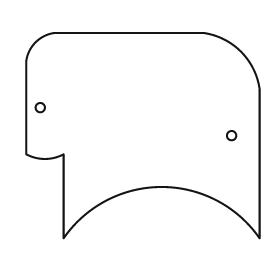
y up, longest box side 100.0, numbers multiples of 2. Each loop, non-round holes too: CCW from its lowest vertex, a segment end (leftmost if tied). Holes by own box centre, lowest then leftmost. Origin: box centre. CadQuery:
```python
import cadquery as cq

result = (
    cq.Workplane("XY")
    .moveTo(-34.0, -44.0)
    .threePointArc((8.0, -22.0), (50.0, -44.0))
    .lineTo(50.0, 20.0)
    .threePointArc((42.0, 36.0), (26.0, 44.0))
    .lineTo(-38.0, 44.0)
    .threePointArc((-46.0, 40.0), (-50.0, 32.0))
    .lineTo(-50.0, -8.0)
    .threePointArc((-42.0, -10.0), (-34.0, -8.0))
    .close()
    .moveTo(38.0, 0.0)
    .circle(2.0)
    .moveTo(-44.0, 12.0)
    .circle(2.0)
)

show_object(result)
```